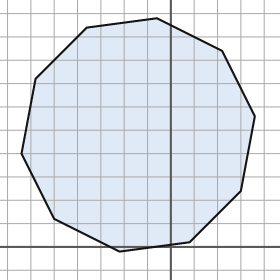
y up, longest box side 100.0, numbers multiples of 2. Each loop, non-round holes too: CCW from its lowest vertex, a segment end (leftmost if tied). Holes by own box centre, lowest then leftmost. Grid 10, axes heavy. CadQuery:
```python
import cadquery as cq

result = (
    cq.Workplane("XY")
    .moveTo(-22.0, -2.0)
    .lineTo(8.0, 2.0)
    .lineTo(30.0, 24.0)
    .lineTo(36.0, 56.0)
    .lineTo(22.0, 84.0)
    .lineTo(-6.0, 98.0)
    .lineTo(-36.0, 94.0)
    .lineTo(-58.0, 72.0)
    .lineTo(-64.0, 40.0)
    .lineTo(-50.0, 12.0)
    .close()
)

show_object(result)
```